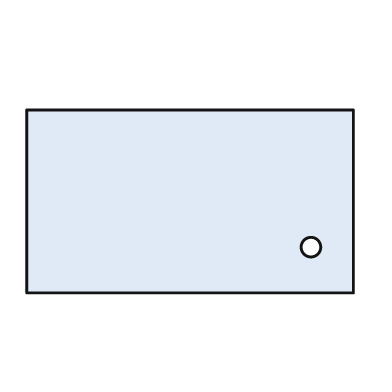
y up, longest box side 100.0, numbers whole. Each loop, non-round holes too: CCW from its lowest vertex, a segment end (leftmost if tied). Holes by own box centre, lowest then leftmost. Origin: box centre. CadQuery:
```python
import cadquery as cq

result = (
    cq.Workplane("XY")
    .moveTo(-50.0, -28.0)
    .lineTo(50.0, -28.0)
    .lineTo(50.0, 28.0)
    .lineTo(-50.0, 28.0)
    .close()
    .moveTo(37.0, -14.0)
    .circle(3.0)
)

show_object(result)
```